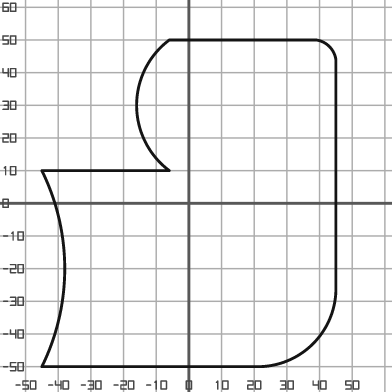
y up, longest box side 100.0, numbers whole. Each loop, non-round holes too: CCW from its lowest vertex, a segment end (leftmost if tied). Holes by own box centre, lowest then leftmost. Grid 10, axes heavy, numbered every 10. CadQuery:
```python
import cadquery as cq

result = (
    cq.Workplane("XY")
    .moveTo(-45.0, -50.0)
    .lineTo(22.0, -50.0)
    .threePointArc((38.0, -43.0), (45.0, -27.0))
    .lineTo(45.0, 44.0)
    .threePointArc((43.0, 48.0), (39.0, 50.0))
    .lineTo(-6.0, 50.0)
    .threePointArc((-16.0, 30.0), (-6.0, 10.0))
    .lineTo(-45.0, 10.0)
    .threePointArc((-38.0, -20.0), (-45.0, -50.0))
    .close()
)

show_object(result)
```